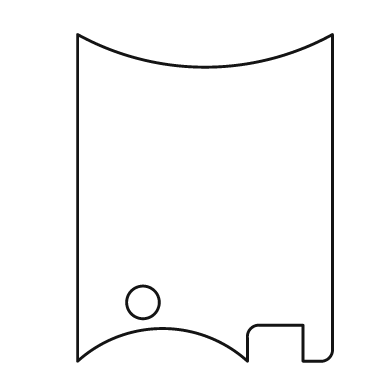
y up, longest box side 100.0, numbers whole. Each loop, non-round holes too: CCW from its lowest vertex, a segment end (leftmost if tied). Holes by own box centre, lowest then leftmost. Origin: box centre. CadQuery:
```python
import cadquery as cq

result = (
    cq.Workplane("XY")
    .moveTo(-39.0, -50.0)
    .threePointArc((-13.0, -40.0), (13.0, -50.0))
    .lineTo(13.0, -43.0)
    .threePointArc((14.0, -40.0), (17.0, -39.0))
    .lineTo(30.0, -39.0)
    .lineTo(30.0, -50.0)
    .lineTo(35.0, -50.0)
    .threePointArc((38.0, -49.0), (39.0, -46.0))
    .lineTo(39.0, 50.0)
    .threePointArc((0.0, 40.0), (-39.0, 50.0))
    .close()
    .moveTo(-19.0, -32.0)
    .circle(5.0)
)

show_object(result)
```